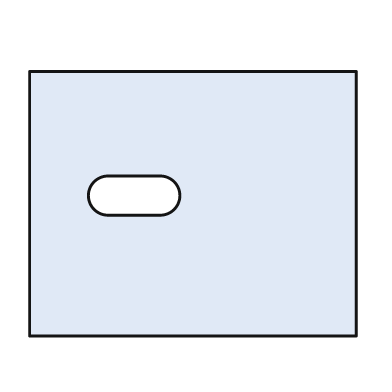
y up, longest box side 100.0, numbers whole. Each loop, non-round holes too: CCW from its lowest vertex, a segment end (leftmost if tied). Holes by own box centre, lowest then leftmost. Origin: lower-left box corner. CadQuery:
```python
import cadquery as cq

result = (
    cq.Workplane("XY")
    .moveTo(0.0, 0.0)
    .lineTo(100.0, 0.0)
    .lineTo(100.0, 81.0)
    .lineTo(0.0, 81.0)
    .close()
    .moveTo(24.0, 37.0)
    .lineTo(40.0, 37.0)
    .threePointArc((46.0, 43.0), (40.0, 49.0))
    .lineTo(24.0, 49.0)
    .threePointArc((18.0, 43.0), (24.0, 37.0))
    .close()
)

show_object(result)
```